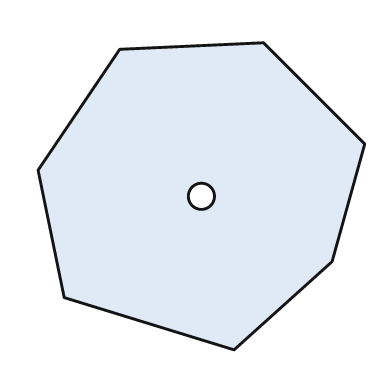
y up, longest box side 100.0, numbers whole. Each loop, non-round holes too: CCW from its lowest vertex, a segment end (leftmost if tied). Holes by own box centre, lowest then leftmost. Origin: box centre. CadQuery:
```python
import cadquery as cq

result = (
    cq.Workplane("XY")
    .moveTo(10.0, -47.0)
    .lineTo(40.0, -20.0)
    .lineTo(50.0, 16.0)
    .lineTo(19.0, 47.0)
    .lineTo(-25.0, 45.0)
    .lineTo(-50.0, 8.0)
    .lineTo(-42.0, -31.0)
    .close()
    .moveTo(0.0, 0.0)
    .circle(4.0)
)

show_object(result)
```